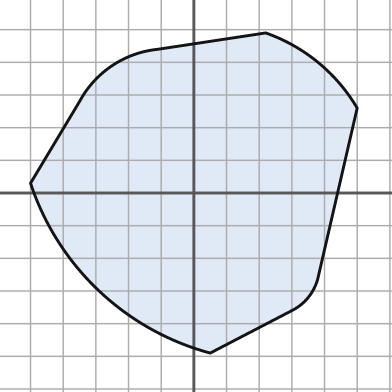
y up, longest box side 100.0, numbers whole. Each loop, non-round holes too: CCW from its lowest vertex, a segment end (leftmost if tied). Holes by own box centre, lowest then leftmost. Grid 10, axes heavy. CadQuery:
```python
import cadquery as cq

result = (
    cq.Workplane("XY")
    .moveTo(5.0, -49.0)
    .lineTo(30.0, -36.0)
    .threePointArc((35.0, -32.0), (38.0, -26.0))
    .lineTo(50.0, 26.0)
    .threePointArc((38.0, 40.0), (22.0, 49.0))
    .lineTo(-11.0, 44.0)
    .threePointArc((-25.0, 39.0), (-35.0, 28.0))
    .lineTo(-50.0, 3.0)
    .threePointArc((-29.0, -30.0), (5.0, -49.0))
    .close()
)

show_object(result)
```